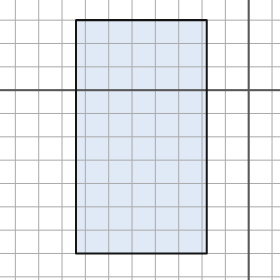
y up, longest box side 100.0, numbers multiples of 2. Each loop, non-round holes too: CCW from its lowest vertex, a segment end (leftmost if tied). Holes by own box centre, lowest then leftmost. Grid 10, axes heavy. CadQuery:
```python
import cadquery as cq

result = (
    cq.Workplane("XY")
    .moveTo(-74.0, -70.0)
    .lineTo(-18.0, -70.0)
    .lineTo(-18.0, 30.0)
    .lineTo(-74.0, 30.0)
    .close()
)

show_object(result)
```